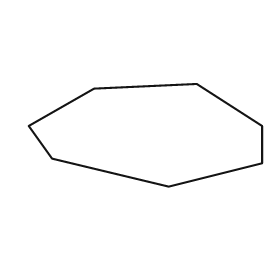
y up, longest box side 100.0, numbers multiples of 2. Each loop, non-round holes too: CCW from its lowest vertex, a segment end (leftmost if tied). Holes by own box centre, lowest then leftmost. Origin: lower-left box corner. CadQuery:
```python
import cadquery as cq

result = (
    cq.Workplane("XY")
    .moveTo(60.0, 0.0)
    .lineTo(100.0, 10.0)
    .lineTo(100.0, 26.0)
    .lineTo(72.0, 44.0)
    .lineTo(28.0, 42.0)
    .lineTo(0.0, 26.0)
    .lineTo(10.0, 12.0)
    .close()
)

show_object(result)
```